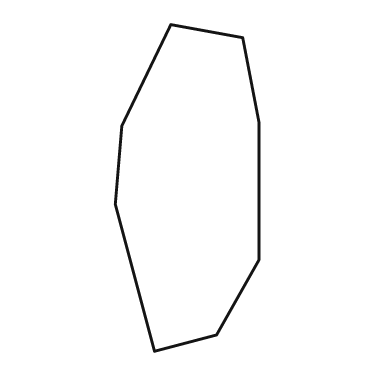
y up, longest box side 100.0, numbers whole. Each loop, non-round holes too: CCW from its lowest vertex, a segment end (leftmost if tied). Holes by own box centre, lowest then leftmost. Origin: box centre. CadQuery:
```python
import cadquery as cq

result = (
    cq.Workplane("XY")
    .moveTo(-10.0, -50.0)
    .lineTo(9.0, -45.0)
    .lineTo(22.0, -22.0)
    .lineTo(22.0, 20.0)
    .lineTo(17.0, 46.0)
    .lineTo(-5.0, 50.0)
    .lineTo(-20.0, 19.0)
    .lineTo(-22.0, -5.0)
    .close()
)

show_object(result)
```